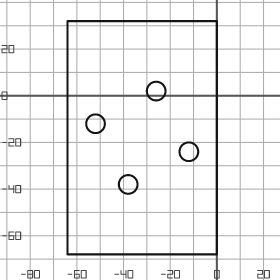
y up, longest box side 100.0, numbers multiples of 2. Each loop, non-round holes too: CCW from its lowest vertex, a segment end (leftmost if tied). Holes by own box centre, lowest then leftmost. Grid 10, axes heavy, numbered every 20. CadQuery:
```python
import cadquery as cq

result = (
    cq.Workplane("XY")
    .moveTo(-64.0, -68.0)
    .lineTo(0.0, -68.0)
    .lineTo(0.0, 32.0)
    .lineTo(-64.0, 32.0)
    .close()
    .moveTo(-38.0, -38.0)
    .circle(4.0)
    .moveTo(-12.0, -24.0)
    .circle(4.0)
    .moveTo(-52.0, -12.0)
    .circle(4.0)
    .moveTo(-26.0, 2.0)
    .circle(4.0)
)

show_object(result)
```